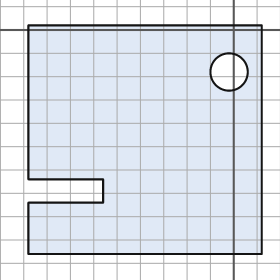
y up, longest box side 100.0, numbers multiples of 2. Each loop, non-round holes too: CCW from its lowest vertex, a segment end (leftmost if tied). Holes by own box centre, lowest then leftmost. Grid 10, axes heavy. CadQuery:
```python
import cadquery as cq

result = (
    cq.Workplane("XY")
    .moveTo(-88.0, -96.0)
    .lineTo(12.0, -96.0)
    .lineTo(12.0, 2.0)
    .lineTo(-88.0, 2.0)
    .lineTo(-88.0, -64.0)
    .lineTo(-56.0, -64.0)
    .lineTo(-56.0, -74.0)
    .lineTo(-88.0, -74.0)
    .close()
    .moveTo(-2.0, -18.0)
    .circle(8.0)
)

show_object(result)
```